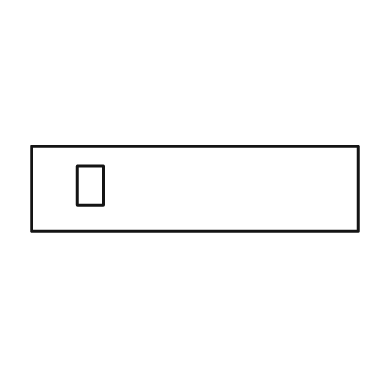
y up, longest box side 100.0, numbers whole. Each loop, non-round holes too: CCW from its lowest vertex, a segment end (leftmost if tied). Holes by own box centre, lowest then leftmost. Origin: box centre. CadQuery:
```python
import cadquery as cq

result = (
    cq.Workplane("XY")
    .moveTo(-50.0, -13.0)
    .lineTo(50.0, -13.0)
    .lineTo(50.0, 13.0)
    .lineTo(-50.0, 13.0)
    .close()
    .moveTo(-36.0, -5.0)
    .lineTo(-28.0, -5.0)
    .lineTo(-28.0, 7.0)
    .lineTo(-36.0, 7.0)
    .close()
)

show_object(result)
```